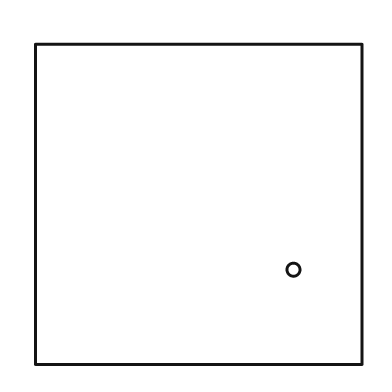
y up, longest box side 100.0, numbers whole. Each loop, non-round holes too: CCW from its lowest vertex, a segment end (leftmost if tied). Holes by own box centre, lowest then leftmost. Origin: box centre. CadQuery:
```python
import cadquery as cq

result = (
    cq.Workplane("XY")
    .moveTo(-50.0, -49.0)
    .lineTo(50.0, -49.0)
    .lineTo(50.0, 49.0)
    .lineTo(-50.0, 49.0)
    .close()
    .moveTo(29.0, -20.0)
    .circle(2.0)
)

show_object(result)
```